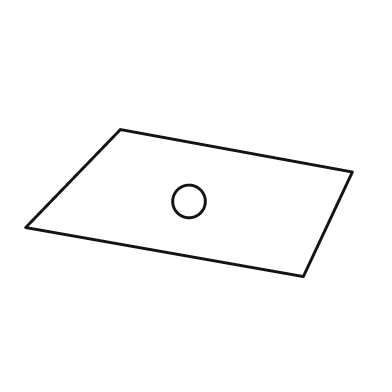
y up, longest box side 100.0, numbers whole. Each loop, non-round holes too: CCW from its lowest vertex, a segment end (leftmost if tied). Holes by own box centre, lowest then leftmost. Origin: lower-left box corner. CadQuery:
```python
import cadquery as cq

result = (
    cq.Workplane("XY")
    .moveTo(85.0, 0.0)
    .lineTo(100.0, 32.0)
    .lineTo(29.0, 45.0)
    .lineTo(0.0, 15.0)
    .close()
    .moveTo(50.0, 23.0)
    .circle(5.0)
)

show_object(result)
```